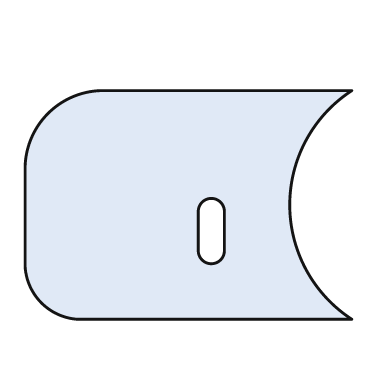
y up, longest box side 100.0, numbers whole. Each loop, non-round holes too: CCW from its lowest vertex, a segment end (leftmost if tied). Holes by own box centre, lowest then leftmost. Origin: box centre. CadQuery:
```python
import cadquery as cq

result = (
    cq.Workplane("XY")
    .moveTo(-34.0, -35.0)
    .lineTo(50.0, -35.0)
    .threePointArc((31.0, 0.0), (50.0, 35.0))
    .lineTo(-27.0, 35.0)
    .threePointArc((-43.0, 28.0), (-50.0, 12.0))
    .lineTo(-50.0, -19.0)
    .threePointArc((-45.0, -30.0), (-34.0, -35.0))
    .close()
    .moveTo(3.0, -14.0)
    .threePointArc((7.0, -18.0), (11.0, -14.0))
    .lineTo(11.0, -2.0)
    .threePointArc((7.0, 2.0), (3.0, -2.0))
    .close()
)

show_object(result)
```